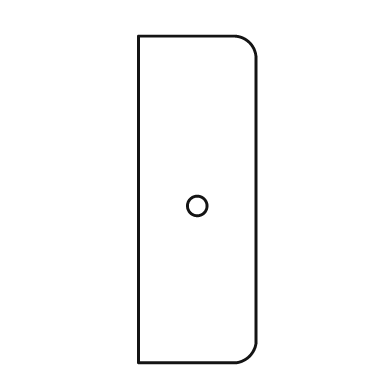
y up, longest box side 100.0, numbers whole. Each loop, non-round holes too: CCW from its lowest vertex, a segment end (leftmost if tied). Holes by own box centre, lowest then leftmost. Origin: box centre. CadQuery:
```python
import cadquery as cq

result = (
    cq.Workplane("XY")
    .moveTo(-18.0, -50.0)
    .lineTo(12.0, -50.0)
    .threePointArc((16.0, -48.0), (18.0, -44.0))
    .lineTo(18.0, 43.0)
    .threePointArc((16.0, 48.0), (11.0, 50.0))
    .lineTo(-18.0, 50.0)
    .close()
    .moveTo(0.0, -2.0)
    .circle(3.0)
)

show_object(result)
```